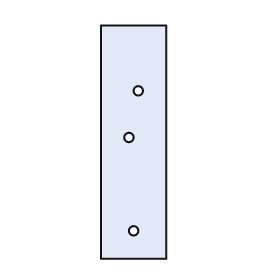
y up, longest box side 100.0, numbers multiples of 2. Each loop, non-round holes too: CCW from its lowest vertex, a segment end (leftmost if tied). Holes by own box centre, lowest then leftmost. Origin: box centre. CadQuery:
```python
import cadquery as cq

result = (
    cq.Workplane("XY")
    .moveTo(-14.0, -50.0)
    .lineTo(14.0, -50.0)
    .lineTo(14.0, 50.0)
    .lineTo(-14.0, 50.0)
    .close()
    .moveTo(0.0, -38.0)
    .circle(2.0)
    .moveTo(-2.0, 2.0)
    .circle(2.0)
    .moveTo(2.0, 22.0)
    .circle(2.0)
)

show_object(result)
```